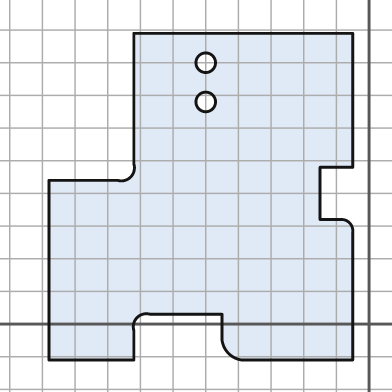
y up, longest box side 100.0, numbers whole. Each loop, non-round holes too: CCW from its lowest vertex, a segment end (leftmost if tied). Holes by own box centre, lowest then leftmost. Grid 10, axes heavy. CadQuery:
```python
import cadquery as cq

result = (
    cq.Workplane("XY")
    .moveTo(-98.0, -11.0)
    .lineTo(-72.0, -11.0)
    .lineTo(-72.0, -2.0)
    .threePointArc((-71.0, 2.0), (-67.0, 3.0))
    .lineTo(-45.0, 3.0)
    .lineTo(-45.0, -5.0)
    .threePointArc((-43.0, -9.0), (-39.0, -11.0))
    .lineTo(-5.0, -11.0)
    .lineTo(-5.0, 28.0)
    .threePointArc((-6.0, 31.0), (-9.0, 32.0))
    .lineTo(-15.0, 32.0)
    .lineTo(-15.0, 48.0)
    .lineTo(-5.0, 48.0)
    .lineTo(-5.0, 89.0)
    .lineTo(-72.0, 89.0)
    .lineTo(-72.0, 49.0)
    .threePointArc((-73.0, 45.0), (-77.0, 44.0))
    .lineTo(-98.0, 44.0)
    .close()
    .moveTo(-50.0, 68.0)
    .circle(3.0)
    .moveTo(-50.0, 80.0)
    .circle(3.0)
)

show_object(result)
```